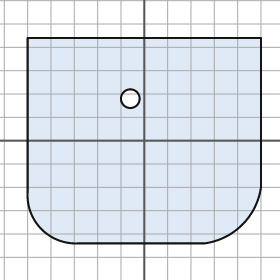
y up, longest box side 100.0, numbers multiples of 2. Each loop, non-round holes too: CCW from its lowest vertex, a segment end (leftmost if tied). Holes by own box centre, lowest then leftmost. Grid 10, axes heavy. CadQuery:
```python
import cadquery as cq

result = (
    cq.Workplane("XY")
    .moveTo(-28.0, -44.0)
    .lineTo(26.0, -44.0)
    .threePointArc((42.0, -36.0), (50.0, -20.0))
    .lineTo(50.0, 44.0)
    .lineTo(-50.0, 44.0)
    .lineTo(-50.0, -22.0)
    .threePointArc((-44.0, -38.0), (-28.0, -44.0))
    .close()
    .moveTo(-6.0, 18.0)
    .circle(4.0)
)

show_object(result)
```